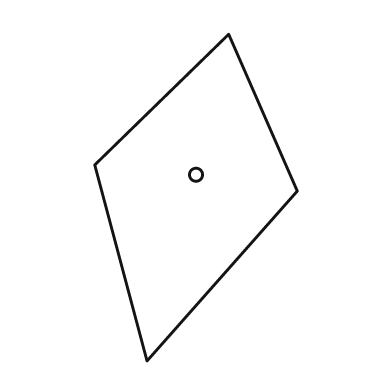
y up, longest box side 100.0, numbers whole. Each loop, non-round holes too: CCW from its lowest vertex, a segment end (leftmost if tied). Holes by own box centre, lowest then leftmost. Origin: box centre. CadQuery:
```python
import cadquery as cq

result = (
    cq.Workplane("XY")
    .moveTo(-15.0, -50.0)
    .lineTo(31.0, 2.0)
    .lineTo(10.0, 50.0)
    .lineTo(-31.0, 10.0)
    .close()
    .moveTo(0.0, 7.0)
    .circle(2.0)
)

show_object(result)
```